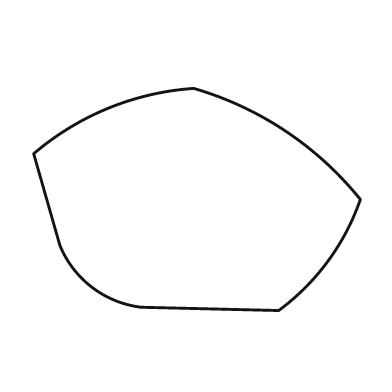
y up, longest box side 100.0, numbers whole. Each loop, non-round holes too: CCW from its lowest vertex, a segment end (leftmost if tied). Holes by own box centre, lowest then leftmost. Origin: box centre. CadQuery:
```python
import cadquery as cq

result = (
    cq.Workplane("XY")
    .moveTo(25.0, -34.0)
    .threePointArc((40.0, -19.0), (50.0, 0.0))
    .threePointArc((27.0, 21.0), (-1.0, 34.0))
    .threePointArc((-27.0, 28.0), (-50.0, 14.0))
    .lineTo(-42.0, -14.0)
    .threePointArc((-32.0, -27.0), (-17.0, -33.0))
    .close()
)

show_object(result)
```